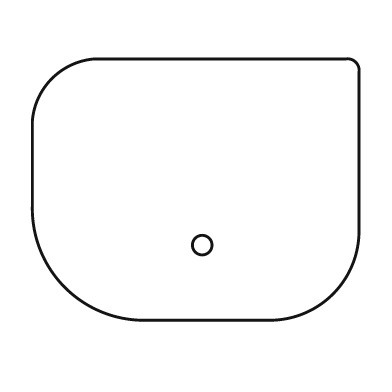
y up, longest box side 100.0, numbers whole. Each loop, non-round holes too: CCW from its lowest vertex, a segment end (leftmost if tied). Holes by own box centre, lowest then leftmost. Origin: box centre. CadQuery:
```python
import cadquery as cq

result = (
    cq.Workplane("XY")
    .moveTo(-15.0, -40.0)
    .lineTo(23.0, -40.0)
    .threePointArc((42.0, -32.0), (50.0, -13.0))
    .lineTo(50.0, 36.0)
    .threePointArc((49.0, 39.0), (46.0, 40.0))
    .lineTo(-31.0, 40.0)
    .threePointArc((-44.0, 34.0), (-50.0, 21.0))
    .lineTo(-50.0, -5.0)
    .threePointArc((-40.0, -30.0), (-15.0, -40.0))
    .close()
    .moveTo(2.0, -17.0)
    .circle(3.0)
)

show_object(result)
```